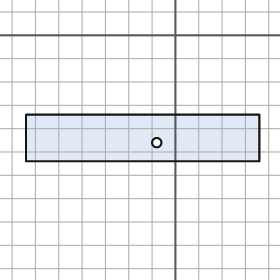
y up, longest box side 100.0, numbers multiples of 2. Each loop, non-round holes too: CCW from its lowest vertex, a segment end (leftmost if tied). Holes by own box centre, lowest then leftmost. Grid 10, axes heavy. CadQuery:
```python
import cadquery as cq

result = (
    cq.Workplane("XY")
    .moveTo(-64.0, -54.0)
    .lineTo(36.0, -54.0)
    .lineTo(36.0, -34.0)
    .lineTo(-64.0, -34.0)
    .close()
    .moveTo(-8.0, -46.0)
    .circle(2.0)
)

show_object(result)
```